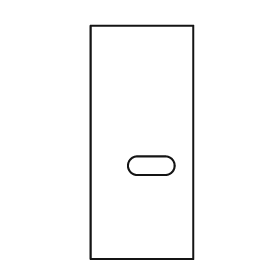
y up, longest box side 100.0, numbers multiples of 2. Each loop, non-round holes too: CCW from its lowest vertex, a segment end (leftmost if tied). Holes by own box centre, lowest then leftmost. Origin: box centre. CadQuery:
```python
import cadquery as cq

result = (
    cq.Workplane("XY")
    .moveTo(-22.0, -50.0)
    .lineTo(22.0, -50.0)
    .lineTo(22.0, 50.0)
    .lineTo(-22.0, 50.0)
    .close()
    .moveTo(-2.0, -14.0)
    .lineTo(10.0, -14.0)
    .threePointArc((14.0, -10.0), (10.0, -6.0))
    .lineTo(-2.0, -6.0)
    .threePointArc((-6.0, -10.0), (-2.0, -14.0))
    .close()
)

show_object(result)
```